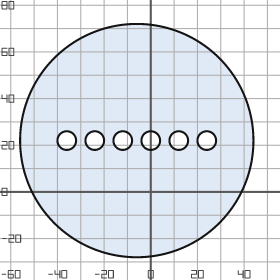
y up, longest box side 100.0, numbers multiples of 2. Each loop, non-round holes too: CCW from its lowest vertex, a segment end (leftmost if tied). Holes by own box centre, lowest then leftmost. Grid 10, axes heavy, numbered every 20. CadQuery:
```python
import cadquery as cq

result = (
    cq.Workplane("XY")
    .moveTo(-6.0, 22.0)
    .circle(50.0)
    .moveTo(-36.0, 22.0)
    .circle(4.0)
    .moveTo(-24.0, 22.0)
    .circle(4.0)
    .moveTo(-12.0, 22.0)
    .circle(4.0)
    .moveTo(0.0, 22.0)
    .circle(4.0)
    .moveTo(12.0, 22.0)
    .circle(4.0)
    .moveTo(24.0, 22.0)
    .circle(4.0)
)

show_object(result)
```